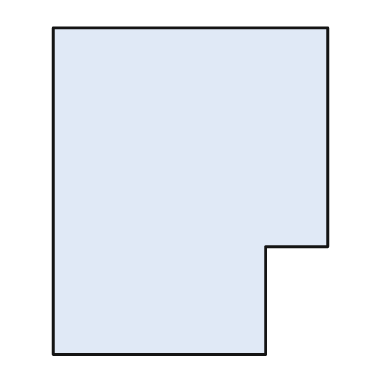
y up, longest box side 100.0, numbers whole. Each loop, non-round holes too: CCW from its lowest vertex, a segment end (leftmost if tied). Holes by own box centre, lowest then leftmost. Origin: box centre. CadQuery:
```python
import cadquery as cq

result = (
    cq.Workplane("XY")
    .moveTo(-42.0, -50.0)
    .lineTo(23.0, -50.0)
    .lineTo(23.0, -17.0)
    .lineTo(42.0, -17.0)
    .lineTo(42.0, 50.0)
    .lineTo(-42.0, 50.0)
    .close()
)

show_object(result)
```